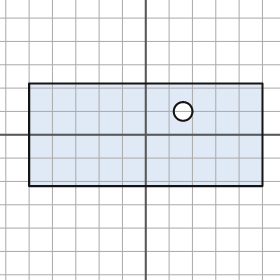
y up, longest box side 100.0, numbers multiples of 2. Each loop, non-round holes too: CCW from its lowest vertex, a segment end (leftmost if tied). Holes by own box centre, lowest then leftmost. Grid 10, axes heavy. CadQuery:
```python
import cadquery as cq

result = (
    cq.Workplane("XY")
    .moveTo(-50.0, -22.0)
    .lineTo(50.0, -22.0)
    .lineTo(50.0, 22.0)
    .lineTo(-50.0, 22.0)
    .close()
    .moveTo(16.0, 10.0)
    .circle(4.0)
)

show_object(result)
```